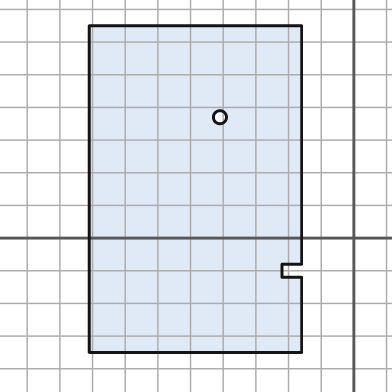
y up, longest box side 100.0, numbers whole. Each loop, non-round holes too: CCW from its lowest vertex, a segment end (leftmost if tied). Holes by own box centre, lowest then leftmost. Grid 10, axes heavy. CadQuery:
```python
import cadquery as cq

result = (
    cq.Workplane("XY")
    .moveTo(-81.0, -35.0)
    .lineTo(-16.0, -35.0)
    .lineTo(-16.0, -12.0)
    .lineTo(-22.0, -12.0)
    .lineTo(-22.0, -8.0)
    .lineTo(-16.0, -8.0)
    .lineTo(-16.0, 65.0)
    .lineTo(-81.0, 65.0)
    .close()
    .moveTo(-41.0, 37.0)
    .circle(2.0)
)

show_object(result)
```